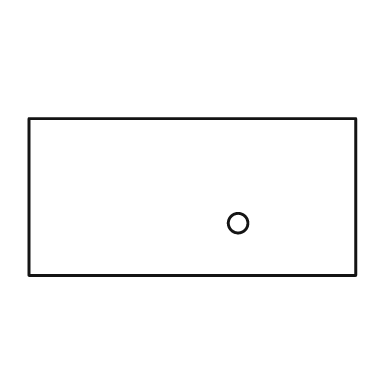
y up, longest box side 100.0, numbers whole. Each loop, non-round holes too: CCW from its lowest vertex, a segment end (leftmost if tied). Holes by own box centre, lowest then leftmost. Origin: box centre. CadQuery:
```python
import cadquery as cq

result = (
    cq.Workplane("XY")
    .moveTo(-50.0, -24.0)
    .lineTo(50.0, -24.0)
    .lineTo(50.0, 24.0)
    .lineTo(-50.0, 24.0)
    .close()
    .moveTo(14.0, -8.0)
    .circle(3.0)
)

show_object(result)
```